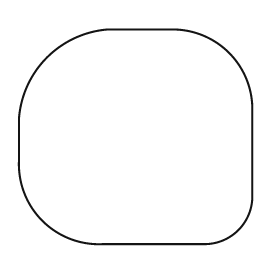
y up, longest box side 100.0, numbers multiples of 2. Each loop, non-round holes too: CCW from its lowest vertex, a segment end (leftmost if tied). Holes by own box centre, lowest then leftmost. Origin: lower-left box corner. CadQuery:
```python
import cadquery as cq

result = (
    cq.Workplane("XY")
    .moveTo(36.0, 0.0)
    .lineTo(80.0, 0.0)
    .threePointArc((94.0, 6.0), (100.0, 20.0))
    .lineTo(100.0, 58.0)
    .threePointArc((90.0, 82.0), (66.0, 92.0))
    .lineTo(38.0, 92.0)
    .threePointArc((12.0, 80.0), (0.0, 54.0))
    .lineTo(0.0, 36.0)
    .threePointArc((10.0, 10.0), (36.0, 0.0))
    .close()
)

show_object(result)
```